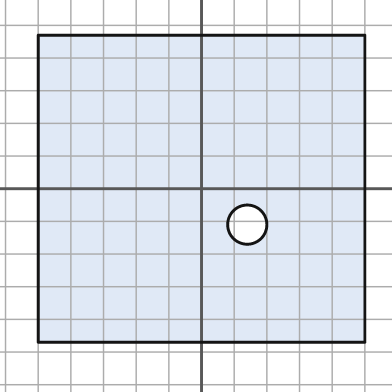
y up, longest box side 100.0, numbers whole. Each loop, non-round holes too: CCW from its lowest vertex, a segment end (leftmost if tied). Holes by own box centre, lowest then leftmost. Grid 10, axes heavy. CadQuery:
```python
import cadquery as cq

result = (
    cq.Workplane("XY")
    .moveTo(-50.0, -47.0)
    .lineTo(50.0, -47.0)
    .lineTo(50.0, 47.0)
    .lineTo(-50.0, 47.0)
    .close()
    .moveTo(14.0, -11.0)
    .circle(6.0)
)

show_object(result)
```